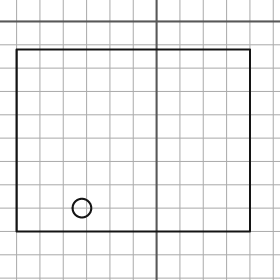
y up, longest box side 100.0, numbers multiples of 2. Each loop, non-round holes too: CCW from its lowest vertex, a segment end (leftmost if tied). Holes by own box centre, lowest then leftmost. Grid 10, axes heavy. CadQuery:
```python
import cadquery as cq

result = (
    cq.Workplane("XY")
    .moveTo(-60.0, -90.0)
    .lineTo(40.0, -90.0)
    .lineTo(40.0, -12.0)
    .lineTo(-60.0, -12.0)
    .close()
    .moveTo(-32.0, -80.0)
    .circle(4.0)
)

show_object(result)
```